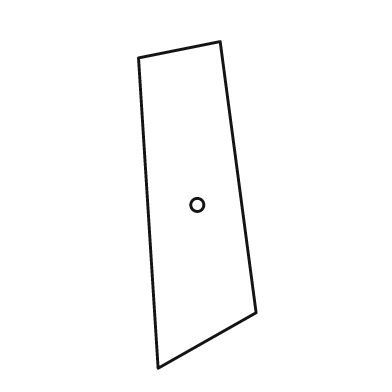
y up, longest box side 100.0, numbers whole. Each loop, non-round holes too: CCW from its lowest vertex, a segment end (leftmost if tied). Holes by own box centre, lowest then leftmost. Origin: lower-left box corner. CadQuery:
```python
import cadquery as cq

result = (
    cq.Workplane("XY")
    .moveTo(6.0, 0.0)
    .lineTo(36.0, 17.0)
    .lineTo(25.0, 100.0)
    .lineTo(0.0, 95.0)
    .close()
    .moveTo(18.0, 50.0)
    .circle(2.0)
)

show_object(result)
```